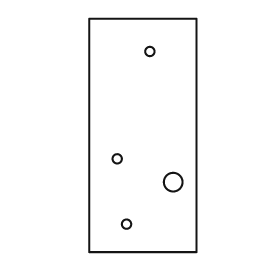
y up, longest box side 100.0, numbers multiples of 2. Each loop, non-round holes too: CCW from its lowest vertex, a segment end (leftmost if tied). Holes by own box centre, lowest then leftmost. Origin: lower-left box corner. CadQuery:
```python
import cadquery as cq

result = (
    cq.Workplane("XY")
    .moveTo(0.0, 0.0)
    .lineTo(46.0, 0.0)
    .lineTo(46.0, 100.0)
    .lineTo(0.0, 100.0)
    .close()
    .moveTo(16.0, 12.0)
    .circle(2.0)
    .moveTo(36.0, 30.0)
    .circle(4.0)
    .moveTo(12.0, 40.0)
    .circle(2.0)
    .moveTo(26.0, 86.0)
    .circle(2.0)
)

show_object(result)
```